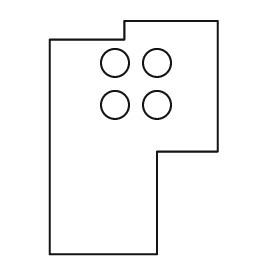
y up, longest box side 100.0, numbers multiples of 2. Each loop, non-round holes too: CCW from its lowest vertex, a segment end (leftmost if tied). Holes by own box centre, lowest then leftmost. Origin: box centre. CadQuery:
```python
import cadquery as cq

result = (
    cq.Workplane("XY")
    .moveTo(-36.0, -50.0)
    .lineTo(10.0, -50.0)
    .lineTo(10.0, -6.0)
    .lineTo(36.0, -6.0)
    .lineTo(36.0, 50.0)
    .lineTo(-4.0, 50.0)
    .lineTo(-4.0, 42.0)
    .lineTo(-36.0, 42.0)
    .close()
    .moveTo(-8.0, 14.0)
    .circle(6.0)
    .moveTo(10.0, 14.0)
    .circle(6.0)
    .moveTo(-8.0, 32.0)
    .circle(6.0)
    .moveTo(10.0, 32.0)
    .circle(6.0)
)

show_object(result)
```